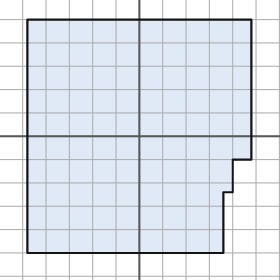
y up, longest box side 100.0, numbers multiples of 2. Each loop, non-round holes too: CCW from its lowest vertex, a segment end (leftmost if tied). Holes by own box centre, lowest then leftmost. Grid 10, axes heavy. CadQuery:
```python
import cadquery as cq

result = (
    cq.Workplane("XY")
    .moveTo(-48.0, -50.0)
    .lineTo(36.0, -50.0)
    .lineTo(36.0, -24.0)
    .lineTo(40.0, -24.0)
    .lineTo(40.0, -10.0)
    .lineTo(48.0, -10.0)
    .lineTo(48.0, 50.0)
    .lineTo(-48.0, 50.0)
    .close()
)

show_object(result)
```